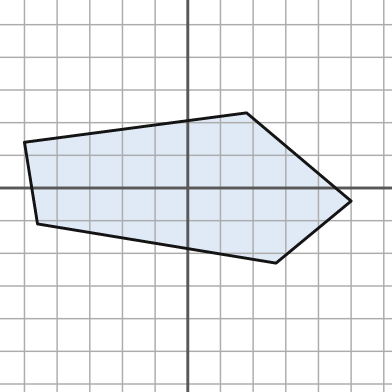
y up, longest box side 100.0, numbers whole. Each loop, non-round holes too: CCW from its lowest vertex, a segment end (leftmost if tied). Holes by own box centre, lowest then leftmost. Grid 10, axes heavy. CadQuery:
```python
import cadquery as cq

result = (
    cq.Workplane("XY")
    .moveTo(27.0, -23.0)
    .lineTo(50.0, -4.0)
    .lineTo(18.0, 23.0)
    .lineTo(-50.0, 14.0)
    .lineTo(-46.0, -11.0)
    .close()
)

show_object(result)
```